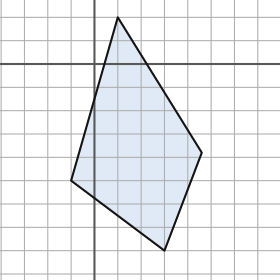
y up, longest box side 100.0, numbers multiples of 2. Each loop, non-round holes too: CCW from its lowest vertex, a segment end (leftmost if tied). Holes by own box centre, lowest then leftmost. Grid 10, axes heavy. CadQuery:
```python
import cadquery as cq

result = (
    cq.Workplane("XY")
    .moveTo(30.0, -80.0)
    .lineTo(46.0, -38.0)
    .lineTo(10.0, 20.0)
    .lineTo(-10.0, -50.0)
    .close()
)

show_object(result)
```